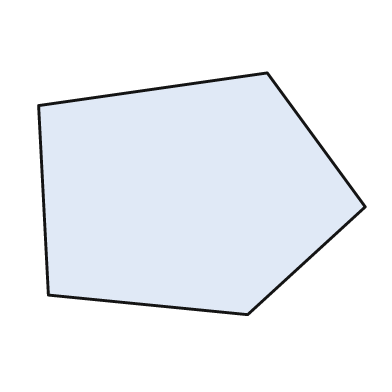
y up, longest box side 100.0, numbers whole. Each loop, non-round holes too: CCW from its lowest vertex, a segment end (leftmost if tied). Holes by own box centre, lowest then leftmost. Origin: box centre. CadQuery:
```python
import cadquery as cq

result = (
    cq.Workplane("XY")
    .moveTo(14.0, -37.0)
    .lineTo(50.0, -4.0)
    .lineTo(20.0, 37.0)
    .lineTo(-50.0, 27.0)
    .lineTo(-47.0, -31.0)
    .close()
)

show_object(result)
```